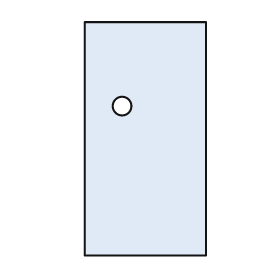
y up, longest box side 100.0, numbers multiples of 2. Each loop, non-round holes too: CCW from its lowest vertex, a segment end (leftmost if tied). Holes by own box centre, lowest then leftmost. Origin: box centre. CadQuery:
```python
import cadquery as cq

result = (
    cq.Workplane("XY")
    .moveTo(-26.0, -50.0)
    .lineTo(26.0, -50.0)
    .lineTo(26.0, 50.0)
    .lineTo(-26.0, 50.0)
    .close()
    .moveTo(-10.0, 14.0)
    .circle(4.0)
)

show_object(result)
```